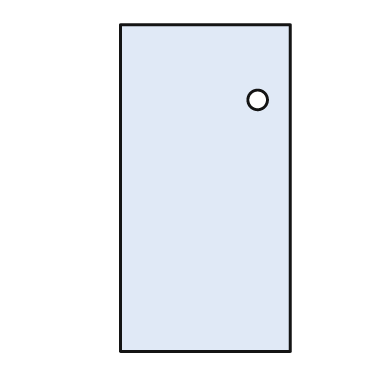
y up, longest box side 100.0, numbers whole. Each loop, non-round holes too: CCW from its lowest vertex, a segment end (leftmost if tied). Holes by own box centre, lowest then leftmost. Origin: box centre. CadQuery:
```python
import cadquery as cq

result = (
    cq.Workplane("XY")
    .moveTo(-26.0, -50.0)
    .lineTo(26.0, -50.0)
    .lineTo(26.0, 50.0)
    .lineTo(-26.0, 50.0)
    .close()
    .moveTo(16.0, 27.0)
    .circle(3.0)
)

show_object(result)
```